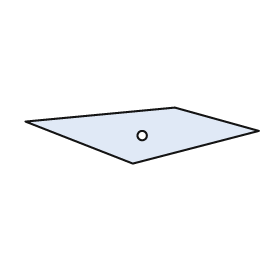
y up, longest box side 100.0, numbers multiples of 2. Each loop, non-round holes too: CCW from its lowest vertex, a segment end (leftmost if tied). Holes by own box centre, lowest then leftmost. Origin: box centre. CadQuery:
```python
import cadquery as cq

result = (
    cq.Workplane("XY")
    .moveTo(-4.0, -12.0)
    .lineTo(50.0, 2.0)
    .lineTo(14.0, 12.0)
    .lineTo(-50.0, 6.0)
    .close()
    .moveTo(0.0, 0.0)
    .circle(2.0)
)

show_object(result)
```